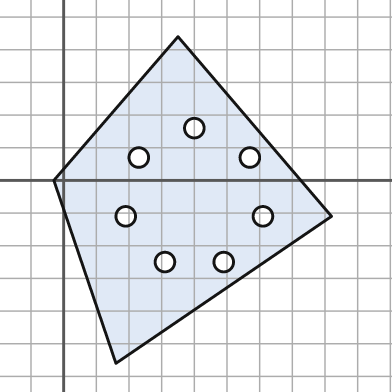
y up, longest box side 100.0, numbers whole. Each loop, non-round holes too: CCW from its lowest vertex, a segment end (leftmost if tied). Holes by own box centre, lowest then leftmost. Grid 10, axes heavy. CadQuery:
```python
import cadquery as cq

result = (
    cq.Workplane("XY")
    .moveTo(16.0, -56.0)
    .lineTo(82.0, -11.0)
    .lineTo(35.0, 44.0)
    .lineTo(-3.0, 0.0)
    .close()
    .moveTo(31.0, -25.0)
    .circle(3.0)
    .moveTo(49.0, -25.0)
    .circle(3.0)
    .moveTo(19.0, -11.0)
    .circle(3.0)
    .moveTo(61.0, -11.0)
    .circle(3.0)
    .moveTo(23.0, 7.0)
    .circle(3.0)
    .moveTo(57.0, 7.0)
    .circle(3.0)
    .moveTo(40.0, 16.0)
    .circle(3.0)
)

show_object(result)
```